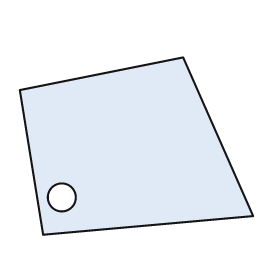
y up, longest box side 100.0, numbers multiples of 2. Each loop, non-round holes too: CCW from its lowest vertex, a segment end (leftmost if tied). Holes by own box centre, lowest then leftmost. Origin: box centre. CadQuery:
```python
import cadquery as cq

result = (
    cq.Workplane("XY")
    .moveTo(-40.0, -38.0)
    .lineTo(50.0, -30.0)
    .lineTo(20.0, 38.0)
    .lineTo(-50.0, 24.0)
    .close()
    .moveTo(-32.0, -22.0)
    .circle(6.0)
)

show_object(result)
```